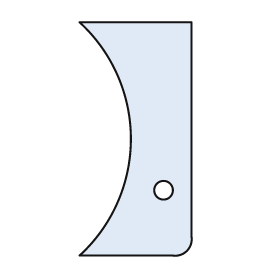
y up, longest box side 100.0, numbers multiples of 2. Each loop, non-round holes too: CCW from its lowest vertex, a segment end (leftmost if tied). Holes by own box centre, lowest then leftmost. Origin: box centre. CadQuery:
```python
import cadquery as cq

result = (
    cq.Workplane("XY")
    .moveTo(-24.0, -50.0)
    .lineTo(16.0, -50.0)
    .threePointArc((22.0, -48.0), (24.0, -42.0))
    .lineTo(24.0, 50.0)
    .lineTo(-24.0, 50.0)
    .threePointArc((-2.0, 0.0), (-24.0, -50.0))
    .close()
    .moveTo(12.0, -22.0)
    .circle(4.0)
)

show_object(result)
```